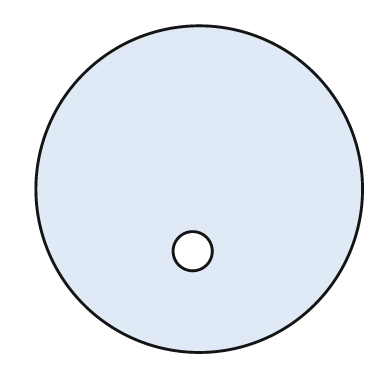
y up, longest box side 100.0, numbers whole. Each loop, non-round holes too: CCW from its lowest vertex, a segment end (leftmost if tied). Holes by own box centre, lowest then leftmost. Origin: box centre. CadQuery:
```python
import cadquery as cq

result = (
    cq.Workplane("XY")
    .moveTo(0.0, 0.0)
    .circle(50.0)
    .moveTo(-2.0, -19.0)
    .circle(6.0)
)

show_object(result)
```